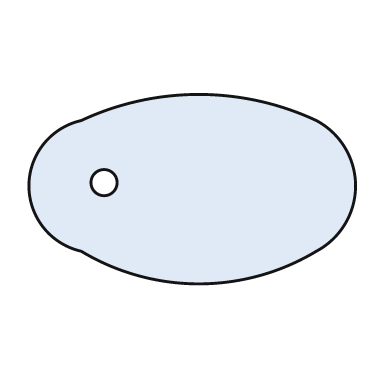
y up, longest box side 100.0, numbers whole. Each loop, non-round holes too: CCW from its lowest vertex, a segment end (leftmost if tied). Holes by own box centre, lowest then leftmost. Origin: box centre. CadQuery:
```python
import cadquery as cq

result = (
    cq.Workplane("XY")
    .moveTo(-34.0, -19.0)
    .threePointArc((2.0, -29.0), (38.0, -19.0))
    .threePointArc((50.0, 1.0), (38.0, 21.0))
    .threePointArc((2.0, 29.0), (-34.0, 21.0))
    .threePointArc((-50.0, 1.0), (-34.0, -19.0))
    .close()
    .moveTo(-27.0, 2.0)
    .circle(4.0)
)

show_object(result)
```